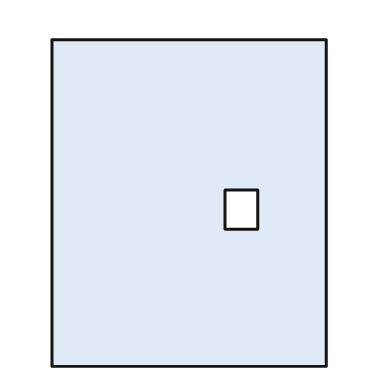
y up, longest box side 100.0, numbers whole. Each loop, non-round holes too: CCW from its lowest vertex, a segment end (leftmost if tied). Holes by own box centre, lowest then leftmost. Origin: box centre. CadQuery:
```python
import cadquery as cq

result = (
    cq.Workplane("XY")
    .moveTo(-42.0, -50.0)
    .lineTo(42.0, -50.0)
    .lineTo(42.0, 50.0)
    .lineTo(-42.0, 50.0)
    .close()
    .moveTo(11.0, -8.0)
    .lineTo(21.0, -8.0)
    .lineTo(21.0, 4.0)
    .lineTo(11.0, 4.0)
    .close()
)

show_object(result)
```